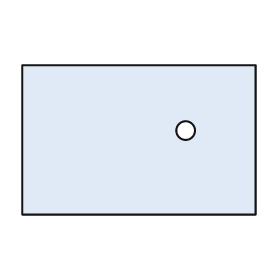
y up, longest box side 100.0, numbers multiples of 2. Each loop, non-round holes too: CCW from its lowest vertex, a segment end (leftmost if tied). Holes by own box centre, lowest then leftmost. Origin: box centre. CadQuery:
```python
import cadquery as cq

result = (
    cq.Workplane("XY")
    .moveTo(-50.0, -32.0)
    .lineTo(50.0, -32.0)
    .lineTo(50.0, 32.0)
    .lineTo(-50.0, 32.0)
    .close()
    .moveTo(20.0, 4.0)
    .circle(4.0)
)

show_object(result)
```